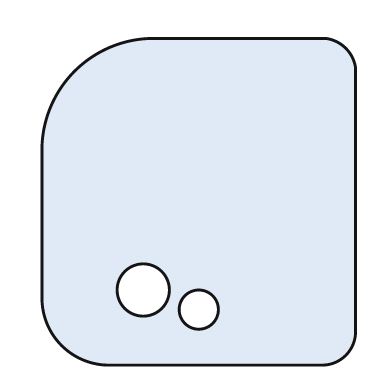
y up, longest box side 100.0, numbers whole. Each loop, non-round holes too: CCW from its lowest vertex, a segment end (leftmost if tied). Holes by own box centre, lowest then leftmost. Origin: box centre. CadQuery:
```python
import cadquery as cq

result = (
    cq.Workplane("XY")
    .moveTo(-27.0, -50.0)
    .lineTo(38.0, -50.0)
    .threePointArc((45.0, -47.0), (48.0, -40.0))
    .lineTo(48.0, 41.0)
    .threePointArc((45.0, 47.0), (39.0, 50.0))
    .lineTo(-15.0, 50.0)
    .threePointArc((-38.0, 40.0), (-48.0, 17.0))
    .lineTo(-48.0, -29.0)
    .threePointArc((-42.0, -44.0), (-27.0, -50.0))
    .close()
    .moveTo(0.0, -33.0)
    .circle(6.0)
    .moveTo(-17.0, -27.0)
    .circle(8.0)
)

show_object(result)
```